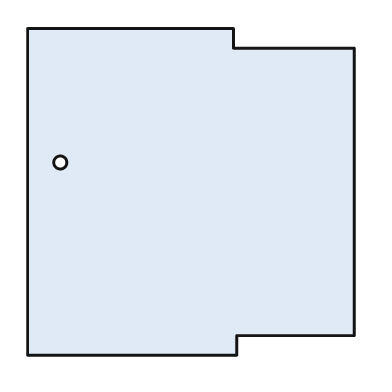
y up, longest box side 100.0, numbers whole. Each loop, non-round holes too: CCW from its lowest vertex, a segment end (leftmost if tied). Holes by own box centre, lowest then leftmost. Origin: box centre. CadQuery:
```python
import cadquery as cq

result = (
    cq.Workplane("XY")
    .moveTo(-50.0, -50.0)
    .lineTo(14.0, -50.0)
    .lineTo(14.0, -44.0)
    .lineTo(50.0, -44.0)
    .lineTo(50.0, 44.0)
    .lineTo(13.0, 44.0)
    .lineTo(13.0, 50.0)
    .lineTo(-50.0, 50.0)
    .close()
    .moveTo(-40.0, 9.0)
    .circle(2.0)
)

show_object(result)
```